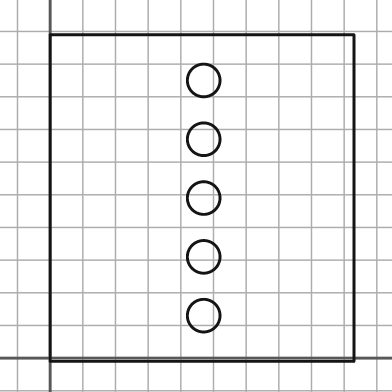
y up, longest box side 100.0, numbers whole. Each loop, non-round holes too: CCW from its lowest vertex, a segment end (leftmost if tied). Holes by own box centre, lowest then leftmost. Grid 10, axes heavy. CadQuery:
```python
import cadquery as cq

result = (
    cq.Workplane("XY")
    .moveTo(0.0, -1.0)
    .lineTo(93.0, -1.0)
    .lineTo(93.0, 99.0)
    .lineTo(0.0, 99.0)
    .close()
    .moveTo(47.0, 13.0)
    .circle(5.0)
    .moveTo(47.0, 31.0)
    .circle(5.0)
    .moveTo(47.0, 49.0)
    .circle(5.0)
    .moveTo(47.0, 67.0)
    .circle(5.0)
    .moveTo(47.0, 85.0)
    .circle(5.0)
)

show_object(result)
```